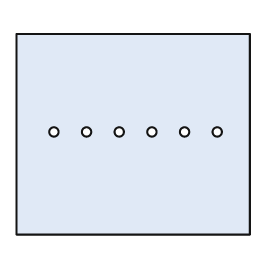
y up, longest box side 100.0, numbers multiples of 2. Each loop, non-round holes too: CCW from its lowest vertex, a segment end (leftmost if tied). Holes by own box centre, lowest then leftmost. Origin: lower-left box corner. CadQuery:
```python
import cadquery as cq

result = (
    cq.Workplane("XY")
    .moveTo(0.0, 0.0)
    .lineTo(100.0, 0.0)
    .lineTo(100.0, 86.0)
    .lineTo(0.0, 86.0)
    .close()
    .moveTo(16.0, 44.0)
    .circle(2.0)
    .moveTo(30.0, 44.0)
    .circle(2.0)
    .moveTo(44.0, 44.0)
    .circle(2.0)
    .moveTo(58.0, 44.0)
    .circle(2.0)
    .moveTo(72.0, 44.0)
    .circle(2.0)
    .moveTo(86.0, 44.0)
    .circle(2.0)
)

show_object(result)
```